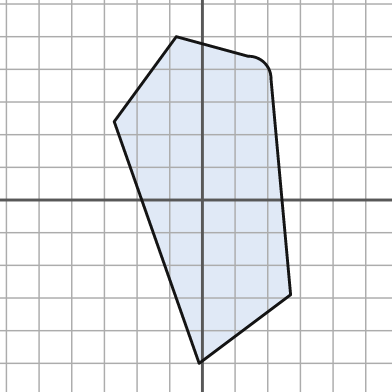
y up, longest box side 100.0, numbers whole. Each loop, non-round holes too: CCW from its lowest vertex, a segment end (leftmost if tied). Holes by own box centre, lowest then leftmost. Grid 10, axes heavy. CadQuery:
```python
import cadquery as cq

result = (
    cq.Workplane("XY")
    .moveTo(-1.0, -50.0)
    .lineTo(27.0, -29.0)
    .lineTo(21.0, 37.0)
    .threePointArc((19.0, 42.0), (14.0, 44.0))
    .lineTo(-8.0, 50.0)
    .lineTo(-27.0, 24.0)
    .close()
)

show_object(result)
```